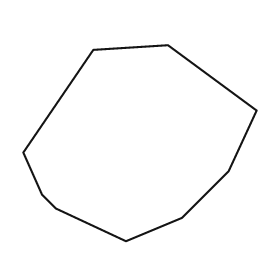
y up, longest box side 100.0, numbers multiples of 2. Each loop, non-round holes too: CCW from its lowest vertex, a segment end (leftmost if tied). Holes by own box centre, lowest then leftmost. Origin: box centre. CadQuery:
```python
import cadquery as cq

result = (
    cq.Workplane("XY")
    .moveTo(-6.0, -42.0)
    .lineTo(18.0, -32.0)
    .lineTo(38.0, -12.0)
    .lineTo(50.0, 14.0)
    .lineTo(12.0, 42.0)
    .lineTo(-20.0, 40.0)
    .lineTo(-50.0, -4.0)
    .lineTo(-42.0, -22.0)
    .lineTo(-36.0, -28.0)
    .close()
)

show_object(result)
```